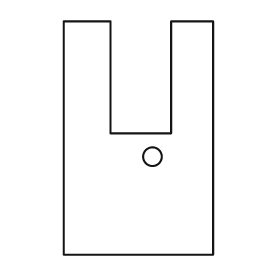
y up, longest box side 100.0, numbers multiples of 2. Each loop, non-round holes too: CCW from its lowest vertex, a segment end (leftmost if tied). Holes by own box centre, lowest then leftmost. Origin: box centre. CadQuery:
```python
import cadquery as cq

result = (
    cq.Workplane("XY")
    .moveTo(-32.0, -50.0)
    .lineTo(32.0, -50.0)
    .lineTo(32.0, 50.0)
    .lineTo(14.0, 50.0)
    .lineTo(14.0, 2.0)
    .lineTo(-12.0, 2.0)
    .lineTo(-12.0, 50.0)
    .lineTo(-32.0, 50.0)
    .close()
    .moveTo(6.0, -8.0)
    .circle(4.0)
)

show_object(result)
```